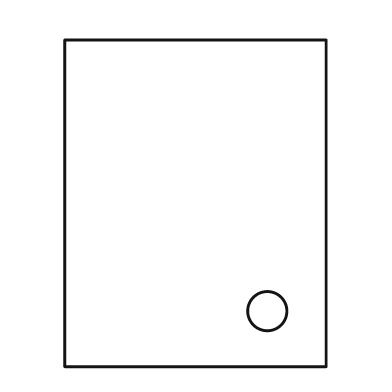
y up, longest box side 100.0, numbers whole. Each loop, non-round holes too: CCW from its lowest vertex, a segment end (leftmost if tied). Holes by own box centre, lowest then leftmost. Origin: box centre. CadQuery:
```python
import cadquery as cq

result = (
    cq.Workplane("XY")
    .moveTo(-40.0, -50.0)
    .lineTo(40.0, -50.0)
    .lineTo(40.0, 50.0)
    .lineTo(-40.0, 50.0)
    .close()
    .moveTo(22.0, -33.0)
    .circle(6.0)
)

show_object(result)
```